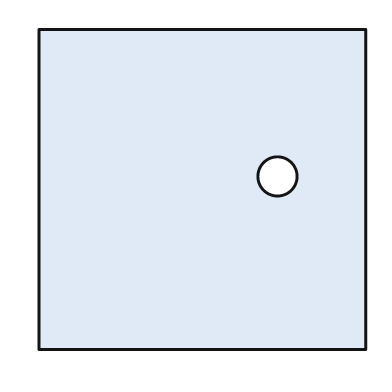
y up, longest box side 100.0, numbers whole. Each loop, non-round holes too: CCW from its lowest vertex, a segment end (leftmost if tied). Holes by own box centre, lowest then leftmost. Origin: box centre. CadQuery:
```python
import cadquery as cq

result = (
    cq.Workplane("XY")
    .moveTo(-50.0, -49.0)
    .lineTo(50.0, -49.0)
    .lineTo(50.0, 49.0)
    .lineTo(-50.0, 49.0)
    .close()
    .moveTo(23.0, 4.0)
    .circle(6.0)
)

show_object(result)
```